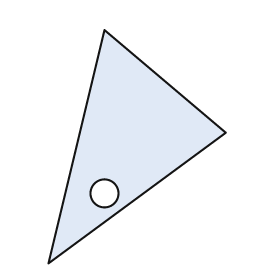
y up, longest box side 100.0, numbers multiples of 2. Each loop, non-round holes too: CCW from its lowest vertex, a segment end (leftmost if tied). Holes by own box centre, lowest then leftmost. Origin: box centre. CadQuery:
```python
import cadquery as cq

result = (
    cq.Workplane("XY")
    .moveTo(-38.0, -50.0)
    .lineTo(38.0, 6.0)
    .lineTo(-14.0, 50.0)
    .close()
    .moveTo(-14.0, -20.0)
    .circle(6.0)
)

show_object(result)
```